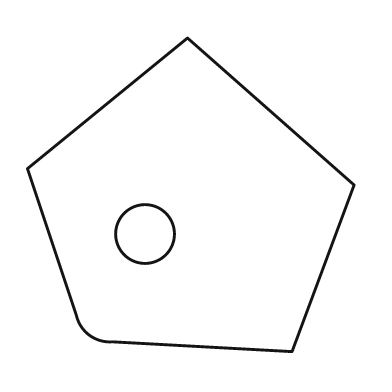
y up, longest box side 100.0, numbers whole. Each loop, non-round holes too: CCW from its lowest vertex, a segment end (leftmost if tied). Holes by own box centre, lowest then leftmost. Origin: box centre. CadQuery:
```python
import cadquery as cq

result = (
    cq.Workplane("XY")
    .moveTo(31.0, -48.0)
    .lineTo(50.0, 3.0)
    .lineTo(-1.0, 48.0)
    .lineTo(-50.0, 8.0)
    .lineTo(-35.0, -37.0)
    .threePointArc((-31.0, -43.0), (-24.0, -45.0))
    .close()
    .moveTo(-14.0, -12.0)
    .circle(9.0)
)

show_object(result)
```